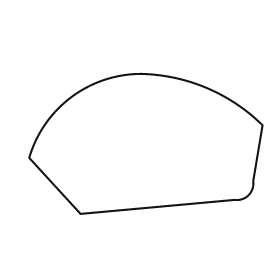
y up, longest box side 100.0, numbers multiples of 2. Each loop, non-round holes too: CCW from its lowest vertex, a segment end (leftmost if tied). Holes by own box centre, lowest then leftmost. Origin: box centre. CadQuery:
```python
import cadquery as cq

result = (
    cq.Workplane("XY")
    .moveTo(-28.0, -30.0)
    .lineTo(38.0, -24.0)
    .threePointArc((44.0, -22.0), (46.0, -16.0))
    .lineTo(50.0, 8.0)
    .threePointArc((26.0, 24.0), (-2.0, 30.0))
    .threePointArc((-32.0, 20.0), (-50.0, -6.0))
    .close()
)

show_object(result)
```